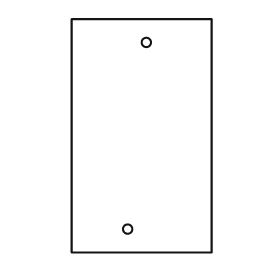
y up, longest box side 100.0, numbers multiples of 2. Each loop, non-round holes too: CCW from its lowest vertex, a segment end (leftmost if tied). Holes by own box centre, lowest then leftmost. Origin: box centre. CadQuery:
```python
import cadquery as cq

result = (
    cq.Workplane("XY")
    .moveTo(-30.0, -50.0)
    .lineTo(30.0, -50.0)
    .lineTo(30.0, 50.0)
    .lineTo(-30.0, 50.0)
    .close()
    .moveTo(-6.0, -40.0)
    .circle(2.0)
    .moveTo(2.0, 40.0)
    .circle(2.0)
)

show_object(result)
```